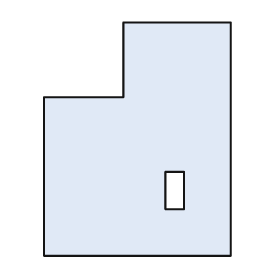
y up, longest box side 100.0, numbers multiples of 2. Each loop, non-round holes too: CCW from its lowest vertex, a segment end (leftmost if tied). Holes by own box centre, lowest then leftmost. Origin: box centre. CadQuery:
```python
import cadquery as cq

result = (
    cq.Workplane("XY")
    .moveTo(-40.0, -50.0)
    .lineTo(40.0, -50.0)
    .lineTo(40.0, 50.0)
    .lineTo(-6.0, 50.0)
    .lineTo(-6.0, 18.0)
    .lineTo(-40.0, 18.0)
    .close()
    .moveTo(12.0, -30.0)
    .lineTo(20.0, -30.0)
    .lineTo(20.0, -14.0)
    .lineTo(12.0, -14.0)
    .close()
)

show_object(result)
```